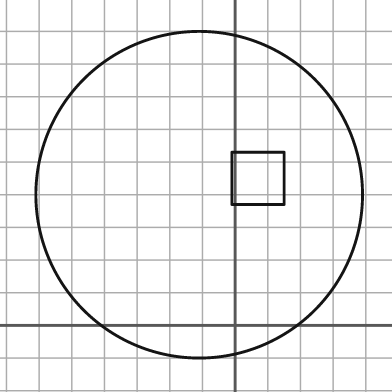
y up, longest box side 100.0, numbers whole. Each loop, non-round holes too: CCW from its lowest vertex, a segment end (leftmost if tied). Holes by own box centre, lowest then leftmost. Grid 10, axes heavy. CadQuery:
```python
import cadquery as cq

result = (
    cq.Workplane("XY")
    .moveTo(-11.0, 40.0)
    .circle(50.0)
    .moveTo(-1.0, 37.0)
    .lineTo(15.0, 37.0)
    .lineTo(15.0, 53.0)
    .lineTo(-1.0, 53.0)
    .close()
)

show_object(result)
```